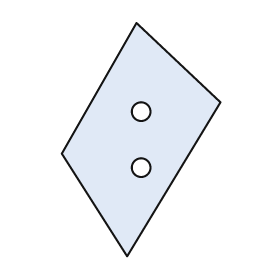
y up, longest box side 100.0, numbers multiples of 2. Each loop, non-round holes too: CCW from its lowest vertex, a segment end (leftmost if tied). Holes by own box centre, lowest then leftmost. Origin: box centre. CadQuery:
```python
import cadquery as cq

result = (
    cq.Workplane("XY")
    .moveTo(-6.0, -50.0)
    .lineTo(34.0, 16.0)
    .lineTo(-2.0, 50.0)
    .lineTo(-34.0, -6.0)
    .close()
    .moveTo(0.0, -12.0)
    .circle(4.0)
    .moveTo(0.0, 12.0)
    .circle(4.0)
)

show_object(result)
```